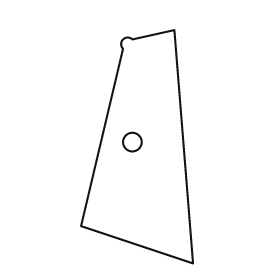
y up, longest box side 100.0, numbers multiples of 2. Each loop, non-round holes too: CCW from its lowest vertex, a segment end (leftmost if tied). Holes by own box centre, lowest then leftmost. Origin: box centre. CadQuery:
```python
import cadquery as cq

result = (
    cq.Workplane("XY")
    .moveTo(24.0, -50.0)
    .lineTo(16.0, 50.0)
    .lineTo(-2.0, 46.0)
    .threePointArc((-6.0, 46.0), (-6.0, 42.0))
    .lineTo(-24.0, -34.0)
    .close()
    .moveTo(-2.0, 2.0)
    .circle(4.0)
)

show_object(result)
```